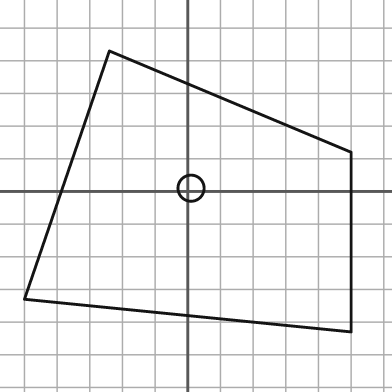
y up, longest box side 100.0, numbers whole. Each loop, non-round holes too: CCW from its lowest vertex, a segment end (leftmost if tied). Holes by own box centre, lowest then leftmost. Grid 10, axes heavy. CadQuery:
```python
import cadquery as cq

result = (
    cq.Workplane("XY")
    .moveTo(50.0, -43.0)
    .lineTo(50.0, 12.0)
    .lineTo(-24.0, 43.0)
    .lineTo(-50.0, -33.0)
    .close()
    .moveTo(1.0, 1.0)
    .circle(4.0)
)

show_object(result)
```